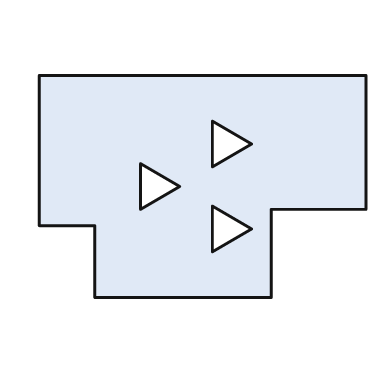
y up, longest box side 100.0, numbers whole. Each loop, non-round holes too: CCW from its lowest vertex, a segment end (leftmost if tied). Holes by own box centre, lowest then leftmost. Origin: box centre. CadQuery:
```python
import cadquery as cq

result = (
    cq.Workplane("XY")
    .moveTo(-33.0, -34.0)
    .lineTo(21.0, -34.0)
    .lineTo(21.0, -7.0)
    .lineTo(50.0, -7.0)
    .lineTo(50.0, 34.0)
    .lineTo(-50.0, 34.0)
    .lineTo(-50.0, -12.0)
    .lineTo(-33.0, -12.0)
    .close()
    .moveTo(3.0, -20.0)
    .lineTo(15.0, -13.0)
    .lineTo(3.0, -6.0)
    .close()
    .moveTo(-19.0, -7.0)
    .lineTo(-7.0, 0.0)
    .lineTo(-19.0, 7.0)
    .close()
    .moveTo(3.0, 6.0)
    .lineTo(15.0, 13.0)
    .lineTo(3.0, 20.0)
    .close()
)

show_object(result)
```